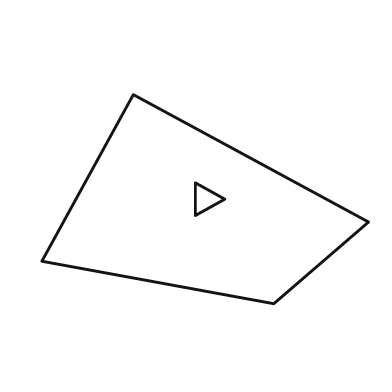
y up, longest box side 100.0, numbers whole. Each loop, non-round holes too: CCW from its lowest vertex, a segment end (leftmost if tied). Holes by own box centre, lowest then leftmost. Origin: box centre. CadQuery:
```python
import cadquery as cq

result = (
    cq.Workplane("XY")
    .moveTo(21.0, -32.0)
    .lineTo(50.0, -7.0)
    .lineTo(-22.0, 32.0)
    .lineTo(-50.0, -19.0)
    .close()
    .moveTo(-3.0, -5.0)
    .lineTo(6.0, 0.0)
    .lineTo(-3.0, 5.0)
    .close()
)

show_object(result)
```